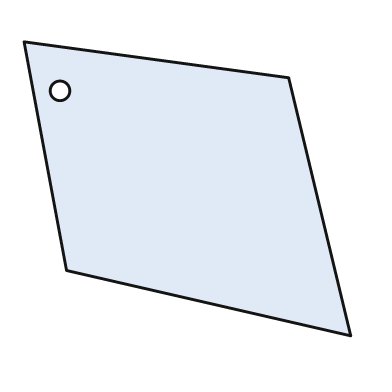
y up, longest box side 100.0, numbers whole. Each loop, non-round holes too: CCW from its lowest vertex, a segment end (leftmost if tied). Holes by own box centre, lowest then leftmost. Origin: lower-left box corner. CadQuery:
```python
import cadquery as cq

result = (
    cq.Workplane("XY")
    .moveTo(100.0, 0.0)
    .lineTo(81.0, 79.0)
    .lineTo(0.0, 90.0)
    .lineTo(13.0, 20.0)
    .close()
    .moveTo(11.0, 75.0)
    .circle(3.0)
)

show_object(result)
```